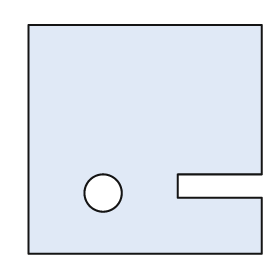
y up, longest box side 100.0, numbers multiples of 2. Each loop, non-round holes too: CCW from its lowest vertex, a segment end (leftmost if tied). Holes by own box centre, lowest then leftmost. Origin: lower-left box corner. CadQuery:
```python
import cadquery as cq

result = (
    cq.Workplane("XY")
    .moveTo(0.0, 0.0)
    .lineTo(100.0, 0.0)
    .lineTo(100.0, 24.0)
    .lineTo(64.0, 24.0)
    .lineTo(64.0, 34.0)
    .lineTo(100.0, 34.0)
    .lineTo(100.0, 98.0)
    .lineTo(0.0, 98.0)
    .close()
    .moveTo(32.0, 26.0)
    .circle(8.0)
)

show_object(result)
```